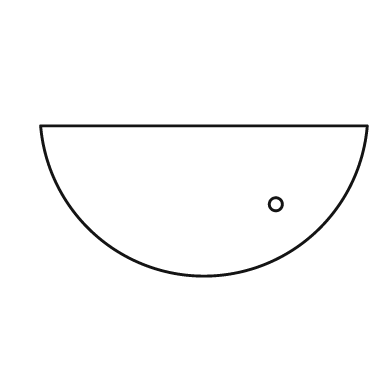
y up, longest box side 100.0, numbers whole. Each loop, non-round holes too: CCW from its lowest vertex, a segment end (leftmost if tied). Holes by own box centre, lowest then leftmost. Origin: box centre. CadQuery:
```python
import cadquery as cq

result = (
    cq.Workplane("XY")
    .moveTo(-50.0, 23.0)
    .threePointArc((0.0, -23.0), (50.0, 23.0))
    .close()
    .moveTo(22.0, -1.0)
    .circle(2.0)
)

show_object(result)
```